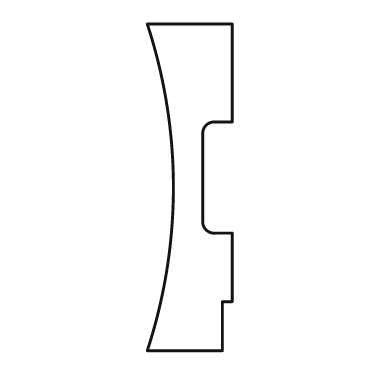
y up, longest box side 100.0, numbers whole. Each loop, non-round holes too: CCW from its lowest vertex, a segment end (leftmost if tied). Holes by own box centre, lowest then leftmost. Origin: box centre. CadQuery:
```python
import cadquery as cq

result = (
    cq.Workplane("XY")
    .moveTo(-13.0, -50.0)
    .lineTo(10.0, -50.0)
    .lineTo(10.0, -35.0)
    .lineTo(13.0, -35.0)
    .lineTo(13.0, -14.0)
    .lineTo(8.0, -14.0)
    .threePointArc((5.0, -13.0), (4.0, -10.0))
    .lineTo(4.0, 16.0)
    .threePointArc((5.0, 19.0), (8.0, 20.0))
    .lineTo(13.0, 20.0)
    .lineTo(13.0, 50.0)
    .lineTo(-13.0, 50.0)
    .threePointArc((-5.0, 0.0), (-13.0, -50.0))
    .close()
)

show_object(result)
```